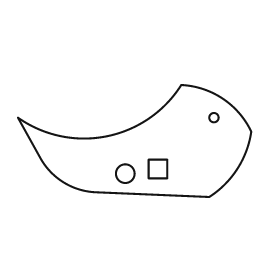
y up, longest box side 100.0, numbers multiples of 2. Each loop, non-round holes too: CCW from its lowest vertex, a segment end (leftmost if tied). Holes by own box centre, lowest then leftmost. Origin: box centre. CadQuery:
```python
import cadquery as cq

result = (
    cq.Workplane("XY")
    .moveTo(32.0, -24.0)
    .threePointArc((44.0, -12.0), (50.0, 4.0))
    .threePointArc((38.0, 18.0), (20.0, 24.0))
    .threePointArc((-12.0, 2.0), (-50.0, 10.0))
    .lineTo(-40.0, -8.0)
    .threePointArc((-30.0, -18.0), (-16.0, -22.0))
    .close()
    .moveTo(-4.0, -14.0)
    .circle(4.0)
    .moveTo(6.0, -16.0)
    .lineTo(14.0, -16.0)
    .lineTo(14.0, -8.0)
    .lineTo(6.0, -8.0)
    .close()
    .moveTo(34.0, 10.0)
    .circle(2.0)
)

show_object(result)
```